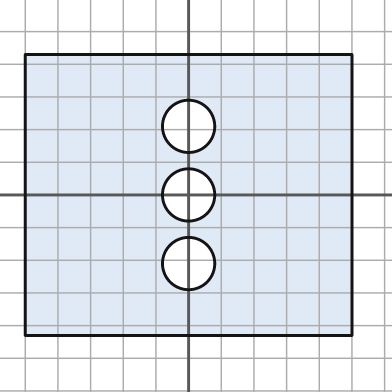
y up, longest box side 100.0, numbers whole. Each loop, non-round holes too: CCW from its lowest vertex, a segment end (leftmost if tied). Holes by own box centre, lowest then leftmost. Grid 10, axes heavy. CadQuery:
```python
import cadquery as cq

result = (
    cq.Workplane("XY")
    .moveTo(-50.0, -43.0)
    .lineTo(50.0, -43.0)
    .lineTo(50.0, 43.0)
    .lineTo(-50.0, 43.0)
    .close()
    .moveTo(0.0, -21.0)
    .circle(8.0)
    .moveTo(0.0, 0.0)
    .circle(8.0)
    .moveTo(0.0, 21.0)
    .circle(8.0)
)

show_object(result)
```